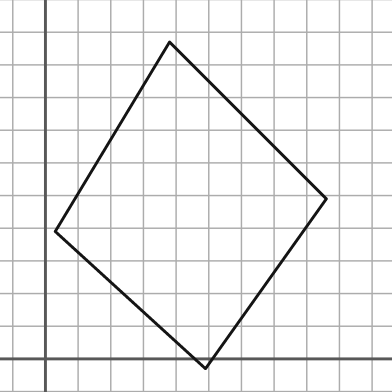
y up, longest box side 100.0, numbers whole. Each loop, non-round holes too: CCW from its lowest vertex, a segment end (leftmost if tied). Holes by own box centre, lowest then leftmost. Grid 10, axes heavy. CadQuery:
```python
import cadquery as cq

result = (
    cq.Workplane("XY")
    .moveTo(49.0, -3.0)
    .lineTo(86.0, 49.0)
    .lineTo(38.0, 97.0)
    .lineTo(3.0, 39.0)
    .close()
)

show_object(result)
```